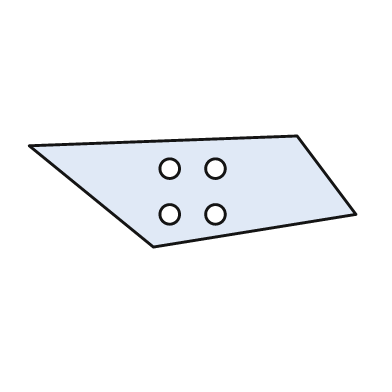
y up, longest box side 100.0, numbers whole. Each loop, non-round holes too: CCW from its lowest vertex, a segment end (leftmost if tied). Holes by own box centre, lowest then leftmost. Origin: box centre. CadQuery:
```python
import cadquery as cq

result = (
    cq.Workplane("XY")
    .moveTo(-12.0, -17.0)
    .lineTo(50.0, -7.0)
    .lineTo(32.0, 17.0)
    .lineTo(-50.0, 14.0)
    .close()
    .moveTo(-7.0, -7.0)
    .circle(3.0)
    .moveTo(7.0, -7.0)
    .circle(3.0)
    .moveTo(-7.0, 7.0)
    .circle(3.0)
    .moveTo(7.0, 7.0)
    .circle(3.0)
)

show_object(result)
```